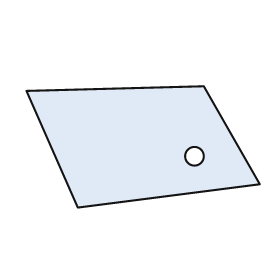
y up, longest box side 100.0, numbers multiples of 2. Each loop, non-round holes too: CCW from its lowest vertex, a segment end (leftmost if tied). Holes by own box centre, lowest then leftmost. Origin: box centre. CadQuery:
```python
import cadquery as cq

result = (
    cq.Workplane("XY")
    .moveTo(-28.0, -26.0)
    .lineTo(50.0, -16.0)
    .lineTo(26.0, 26.0)
    .lineTo(-50.0, 24.0)
    .close()
    .moveTo(22.0, -4.0)
    .circle(4.0)
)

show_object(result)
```